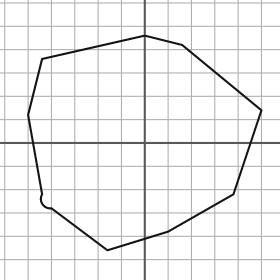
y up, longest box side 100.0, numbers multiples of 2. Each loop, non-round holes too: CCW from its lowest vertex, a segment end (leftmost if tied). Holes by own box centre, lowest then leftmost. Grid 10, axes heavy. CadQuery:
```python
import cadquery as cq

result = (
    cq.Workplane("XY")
    .moveTo(-16.0, -46.0)
    .lineTo(10.0, -38.0)
    .lineTo(38.0, -22.0)
    .lineTo(50.0, 14.0)
    .lineTo(16.0, 42.0)
    .lineTo(0.0, 46.0)
    .lineTo(-44.0, 36.0)
    .lineTo(-50.0, 12.0)
    .lineTo(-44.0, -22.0)
    .threePointArc((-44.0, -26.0), (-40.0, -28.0))
    .close()
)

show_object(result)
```